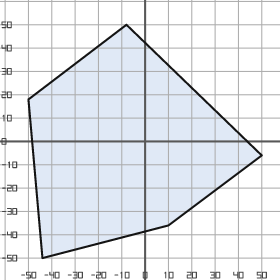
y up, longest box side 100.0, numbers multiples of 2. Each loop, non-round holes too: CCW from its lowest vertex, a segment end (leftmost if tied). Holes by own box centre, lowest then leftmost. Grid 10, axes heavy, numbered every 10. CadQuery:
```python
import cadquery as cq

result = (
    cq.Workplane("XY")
    .moveTo(-44.0, -50.0)
    .lineTo(10.0, -36.0)
    .lineTo(50.0, -6.0)
    .lineTo(-8.0, 50.0)
    .lineTo(-50.0, 18.0)
    .close()
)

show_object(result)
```